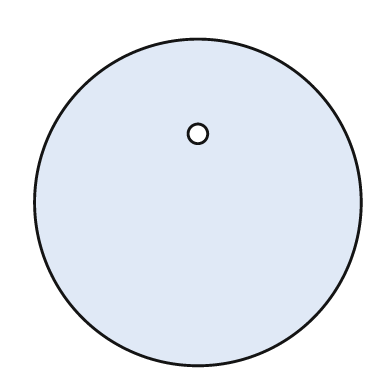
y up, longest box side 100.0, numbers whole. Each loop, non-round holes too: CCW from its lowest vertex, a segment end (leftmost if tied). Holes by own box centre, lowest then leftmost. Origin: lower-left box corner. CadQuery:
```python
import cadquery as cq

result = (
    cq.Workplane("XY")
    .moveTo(50.0, 50.0)
    .circle(50.0)
    .moveTo(50.0, 71.0)
    .circle(3.0)
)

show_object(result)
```